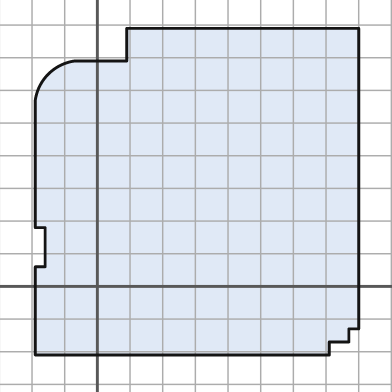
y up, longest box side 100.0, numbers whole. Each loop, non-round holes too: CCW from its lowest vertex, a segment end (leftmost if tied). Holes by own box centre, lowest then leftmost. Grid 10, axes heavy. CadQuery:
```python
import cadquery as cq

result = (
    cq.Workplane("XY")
    .moveTo(-19.0, -21.0)
    .lineTo(71.0, -21.0)
    .lineTo(71.0, -17.0)
    .lineTo(77.0, -17.0)
    .lineTo(77.0, -13.0)
    .lineTo(80.0, -13.0)
    .lineTo(80.0, 79.0)
    .lineTo(9.0, 79.0)
    .lineTo(9.0, 69.0)
    .lineTo(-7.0, 69.0)
    .threePointArc((-15.0, 65.0), (-19.0, 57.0))
    .lineTo(-19.0, 18.0)
    .lineTo(-16.0, 18.0)
    .lineTo(-16.0, 6.0)
    .lineTo(-19.0, 6.0)
    .close()
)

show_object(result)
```